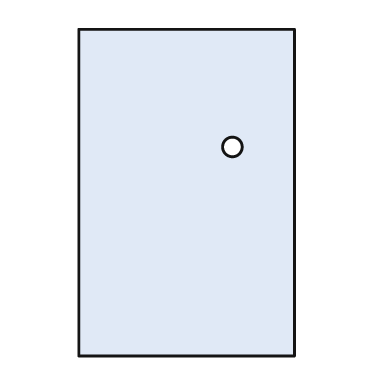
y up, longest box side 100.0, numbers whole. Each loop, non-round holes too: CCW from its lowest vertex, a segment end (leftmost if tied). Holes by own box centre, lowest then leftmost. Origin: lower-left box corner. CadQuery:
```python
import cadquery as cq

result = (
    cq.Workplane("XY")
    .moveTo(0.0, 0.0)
    .lineTo(66.0, 0.0)
    .lineTo(66.0, 100.0)
    .lineTo(0.0, 100.0)
    .close()
    .moveTo(47.0, 64.0)
    .circle(3.0)
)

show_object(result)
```